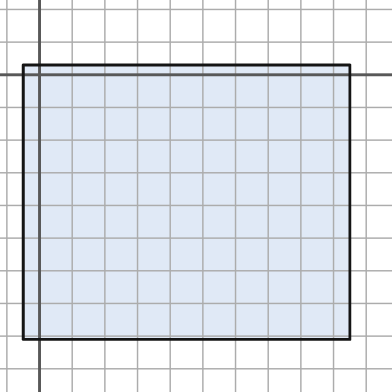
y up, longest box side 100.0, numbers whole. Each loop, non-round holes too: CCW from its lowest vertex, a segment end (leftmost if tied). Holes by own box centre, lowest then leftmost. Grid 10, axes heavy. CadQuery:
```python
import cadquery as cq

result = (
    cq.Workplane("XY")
    .moveTo(-5.0, -81.0)
    .lineTo(95.0, -81.0)
    .lineTo(95.0, 3.0)
    .lineTo(-5.0, 3.0)
    .close()
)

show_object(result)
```